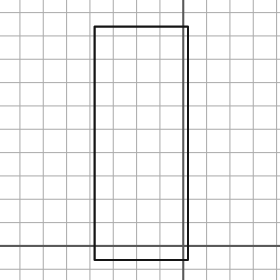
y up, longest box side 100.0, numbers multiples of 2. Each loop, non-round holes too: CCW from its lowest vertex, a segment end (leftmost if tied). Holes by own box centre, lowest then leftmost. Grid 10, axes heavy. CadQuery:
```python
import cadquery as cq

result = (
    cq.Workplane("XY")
    .moveTo(-38.0, -6.0)
    .lineTo(2.0, -6.0)
    .lineTo(2.0, 94.0)
    .lineTo(-38.0, 94.0)
    .close()
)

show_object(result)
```